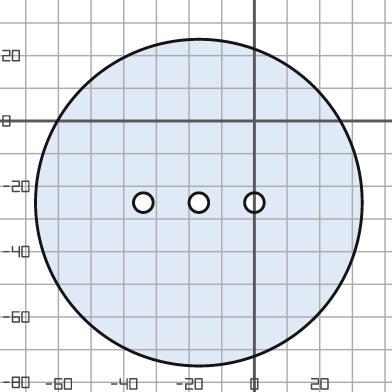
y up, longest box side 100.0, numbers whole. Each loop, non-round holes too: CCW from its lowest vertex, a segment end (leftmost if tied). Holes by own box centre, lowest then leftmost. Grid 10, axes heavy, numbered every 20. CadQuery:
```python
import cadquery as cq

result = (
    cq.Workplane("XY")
    .moveTo(-17.0, -25.0)
    .circle(50.0)
    .moveTo(-34.0, -25.0)
    .circle(3.0)
    .moveTo(-17.0, -25.0)
    .circle(3.0)
    .moveTo(0.0, -25.0)
    .circle(3.0)
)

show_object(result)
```